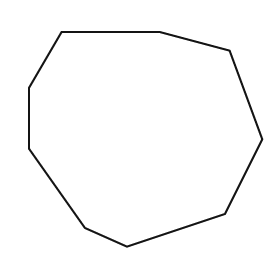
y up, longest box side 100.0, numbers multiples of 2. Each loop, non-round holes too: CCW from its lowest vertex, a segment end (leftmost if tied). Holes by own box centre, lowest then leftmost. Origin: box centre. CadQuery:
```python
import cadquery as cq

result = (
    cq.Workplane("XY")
    .moveTo(-8.0, -46.0)
    .lineTo(34.0, -32.0)
    .lineTo(50.0, 0.0)
    .lineTo(36.0, 38.0)
    .lineTo(6.0, 46.0)
    .lineTo(-36.0, 46.0)
    .lineTo(-50.0, 22.0)
    .lineTo(-50.0, -4.0)
    .lineTo(-26.0, -38.0)
    .close()
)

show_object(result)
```